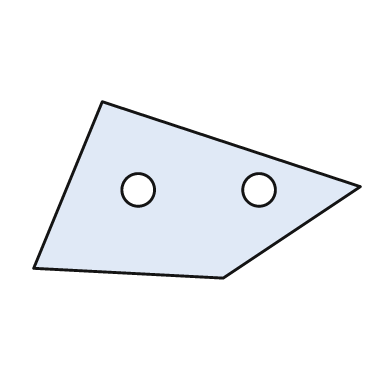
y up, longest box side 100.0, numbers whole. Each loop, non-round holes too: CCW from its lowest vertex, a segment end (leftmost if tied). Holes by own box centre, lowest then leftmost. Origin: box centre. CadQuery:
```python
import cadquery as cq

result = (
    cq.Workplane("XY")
    .moveTo(8.0, -27.0)
    .lineTo(50.0, 1.0)
    .lineTo(-29.0, 27.0)
    .lineTo(-50.0, -24.0)
    .close()
    .moveTo(-18.0, 0.0)
    .circle(5.0)
    .moveTo(19.0, 0.0)
    .circle(5.0)
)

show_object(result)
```